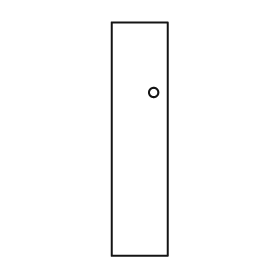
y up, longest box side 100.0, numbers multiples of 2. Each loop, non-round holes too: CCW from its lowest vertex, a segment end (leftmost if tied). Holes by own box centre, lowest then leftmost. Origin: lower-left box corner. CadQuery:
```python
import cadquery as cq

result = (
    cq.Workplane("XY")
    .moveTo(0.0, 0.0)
    .lineTo(24.0, 0.0)
    .lineTo(24.0, 100.0)
    .lineTo(0.0, 100.0)
    .close()
    .moveTo(18.0, 70.0)
    .circle(2.0)
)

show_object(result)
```